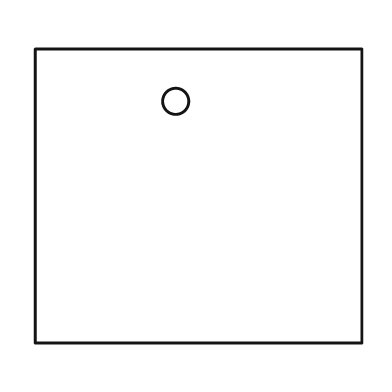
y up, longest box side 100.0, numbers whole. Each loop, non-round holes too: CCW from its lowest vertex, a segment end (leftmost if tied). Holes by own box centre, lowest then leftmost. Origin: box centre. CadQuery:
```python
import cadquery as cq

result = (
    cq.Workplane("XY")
    .moveTo(-50.0, -45.0)
    .lineTo(50.0, -45.0)
    .lineTo(50.0, 45.0)
    .lineTo(-50.0, 45.0)
    .close()
    .moveTo(-7.0, 29.0)
    .circle(4.0)
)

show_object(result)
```